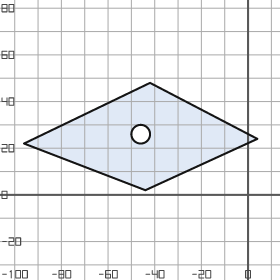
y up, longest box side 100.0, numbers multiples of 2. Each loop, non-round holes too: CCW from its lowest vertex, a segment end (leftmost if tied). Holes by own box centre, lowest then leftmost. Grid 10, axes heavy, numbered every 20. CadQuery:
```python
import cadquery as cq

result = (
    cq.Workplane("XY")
    .moveTo(-44.0, 2.0)
    .lineTo(4.0, 24.0)
    .lineTo(-42.0, 48.0)
    .lineTo(-96.0, 22.0)
    .close()
    .moveTo(-46.0, 26.0)
    .circle(4.0)
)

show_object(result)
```